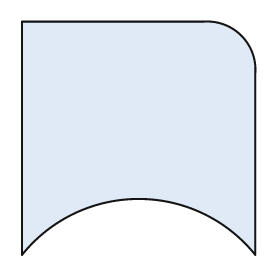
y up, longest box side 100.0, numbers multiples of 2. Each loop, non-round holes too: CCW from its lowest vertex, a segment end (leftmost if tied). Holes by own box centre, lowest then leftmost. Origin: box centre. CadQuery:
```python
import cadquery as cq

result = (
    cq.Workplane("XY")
    .moveTo(-50.0, -50.0)
    .threePointArc((0.0, -26.0), (50.0, -50.0))
    .lineTo(50.0, 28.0)
    .threePointArc((44.0, 44.0), (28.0, 50.0))
    .lineTo(-50.0, 50.0)
    .close()
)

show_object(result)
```